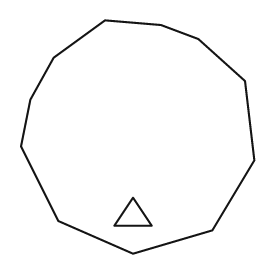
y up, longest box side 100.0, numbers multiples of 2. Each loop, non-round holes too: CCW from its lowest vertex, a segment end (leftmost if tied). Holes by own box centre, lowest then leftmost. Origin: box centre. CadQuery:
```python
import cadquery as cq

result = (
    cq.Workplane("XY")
    .moveTo(-2.0, -50.0)
    .lineTo(32.0, -40.0)
    .lineTo(50.0, -10.0)
    .lineTo(46.0, 24.0)
    .lineTo(26.0, 42.0)
    .lineTo(10.0, 48.0)
    .lineTo(-14.0, 50.0)
    .lineTo(-36.0, 34.0)
    .lineTo(-46.0, 16.0)
    .lineTo(-50.0, -4.0)
    .lineTo(-34.0, -36.0)
    .close()
    .moveTo(-10.0, -38.0)
    .lineTo(6.0, -38.0)
    .lineTo(-2.0, -26.0)
    .close()
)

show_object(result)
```